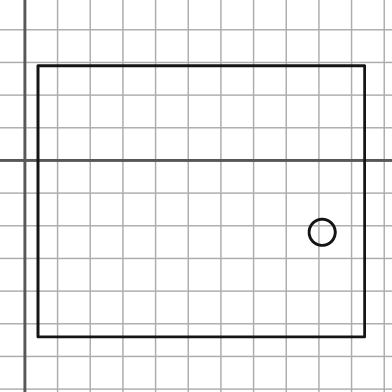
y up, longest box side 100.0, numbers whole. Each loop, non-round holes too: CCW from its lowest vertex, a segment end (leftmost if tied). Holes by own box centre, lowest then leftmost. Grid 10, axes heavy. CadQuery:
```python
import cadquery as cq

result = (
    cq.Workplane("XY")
    .moveTo(4.0, -54.0)
    .lineTo(104.0, -54.0)
    .lineTo(104.0, 29.0)
    .lineTo(4.0, 29.0)
    .close()
    .moveTo(91.0, -22.0)
    .circle(4.0)
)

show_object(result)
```